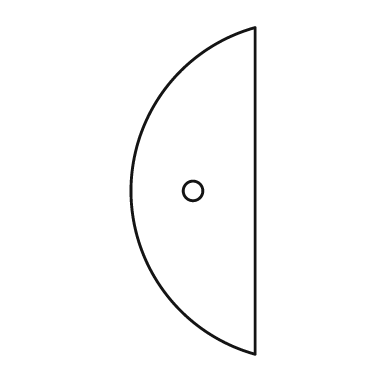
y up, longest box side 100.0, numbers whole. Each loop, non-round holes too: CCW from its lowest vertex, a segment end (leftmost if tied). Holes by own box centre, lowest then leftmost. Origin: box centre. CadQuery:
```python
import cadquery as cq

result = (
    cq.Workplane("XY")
    .moveTo(19.0, -50.0)
    .lineTo(19.0, 50.0)
    .threePointArc((-19.0, 0.0), (19.0, -50.0))
    .close()
    .moveTo(0.0, 0.0)
    .circle(3.0)
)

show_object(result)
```